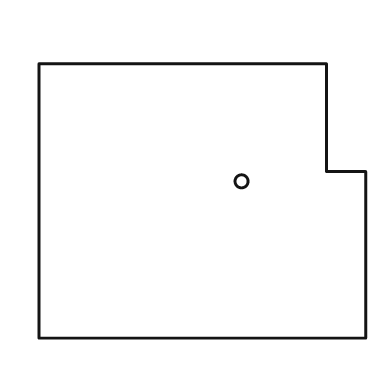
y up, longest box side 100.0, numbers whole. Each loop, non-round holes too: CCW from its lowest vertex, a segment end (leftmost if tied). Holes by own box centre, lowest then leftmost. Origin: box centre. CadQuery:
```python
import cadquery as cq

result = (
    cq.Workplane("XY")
    .moveTo(-50.0, -42.0)
    .lineTo(50.0, -42.0)
    .lineTo(50.0, 9.0)
    .lineTo(38.0, 9.0)
    .lineTo(38.0, 42.0)
    .lineTo(-50.0, 42.0)
    .close()
    .moveTo(12.0, 6.0)
    .circle(2.0)
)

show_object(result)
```